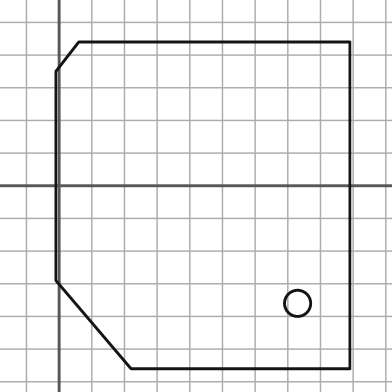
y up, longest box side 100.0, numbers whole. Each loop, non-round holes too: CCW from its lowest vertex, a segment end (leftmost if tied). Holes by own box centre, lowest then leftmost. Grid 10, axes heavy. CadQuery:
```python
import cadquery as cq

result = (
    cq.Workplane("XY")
    .moveTo(22.0, -56.0)
    .lineTo(89.0, -56.0)
    .lineTo(89.0, 44.0)
    .lineTo(6.0, 44.0)
    .lineTo(-1.0, 35.0)
    .lineTo(-1.0, -29.0)
    .close()
    .moveTo(73.0, -36.0)
    .circle(4.0)
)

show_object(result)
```